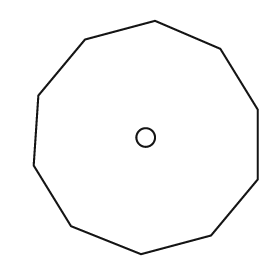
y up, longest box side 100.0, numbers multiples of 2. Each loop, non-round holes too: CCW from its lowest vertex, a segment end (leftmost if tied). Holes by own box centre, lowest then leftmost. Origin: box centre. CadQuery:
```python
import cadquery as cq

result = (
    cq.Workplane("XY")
    .moveTo(-2.0, -50.0)
    .lineTo(28.0, -42.0)
    .lineTo(48.0, -18.0)
    .lineTo(48.0, 12.0)
    .lineTo(32.0, 38.0)
    .lineTo(4.0, 50.0)
    .lineTo(-26.0, 42.0)
    .lineTo(-46.0, 18.0)
    .lineTo(-48.0, -12.0)
    .lineTo(-32.0, -38.0)
    .close()
    .moveTo(0.0, 0.0)
    .circle(4.0)
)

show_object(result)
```